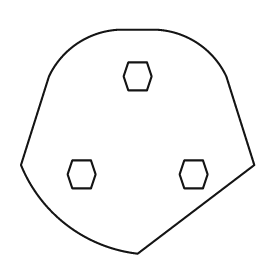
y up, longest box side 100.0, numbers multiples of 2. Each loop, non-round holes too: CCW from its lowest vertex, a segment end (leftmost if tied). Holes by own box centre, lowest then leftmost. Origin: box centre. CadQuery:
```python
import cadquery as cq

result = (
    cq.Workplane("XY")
    .moveTo(0.0, -48.0)
    .lineTo(50.0, -10.0)
    .lineTo(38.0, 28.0)
    .threePointArc((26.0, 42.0), (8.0, 48.0))
    .lineTo(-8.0, 48.0)
    .threePointArc((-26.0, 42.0), (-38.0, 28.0))
    .lineTo(-50.0, -10.0)
    .threePointArc((-30.0, -36.0), (0.0, -48.0))
    .close()
    .moveTo(-28.0, -20.0)
    .lineTo(-20.0, -20.0)
    .lineTo(-18.0, -14.0)
    .lineTo(-20.0, -8.0)
    .lineTo(-28.0, -8.0)
    .lineTo(-30.0, -14.0)
    .close()
    .moveTo(20.0, -20.0)
    .lineTo(28.0, -20.0)
    .lineTo(30.0, -14.0)
    .lineTo(28.0, -8.0)
    .lineTo(20.0, -8.0)
    .lineTo(18.0, -14.0)
    .close()
    .moveTo(-4.0, 22.0)
    .lineTo(4.0, 22.0)
    .lineTo(6.0, 28.0)
    .lineTo(4.0, 34.0)
    .lineTo(-4.0, 34.0)
    .lineTo(-6.0, 28.0)
    .close()
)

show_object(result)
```